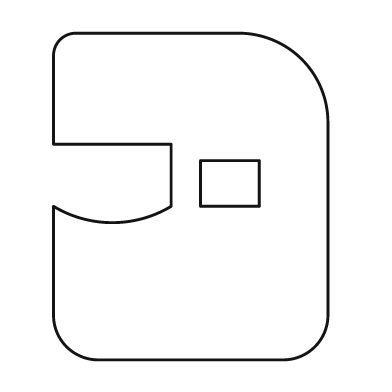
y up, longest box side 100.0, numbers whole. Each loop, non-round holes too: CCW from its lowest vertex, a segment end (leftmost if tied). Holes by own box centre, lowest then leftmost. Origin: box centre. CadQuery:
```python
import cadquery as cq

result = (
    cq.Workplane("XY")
    .moveTo(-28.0, -50.0)
    .lineTo(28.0, -50.0)
    .threePointArc((38.0, -46.0), (42.0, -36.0))
    .lineTo(42.0, 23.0)
    .threePointArc((34.0, 42.0), (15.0, 50.0))
    .lineTo(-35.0, 50.0)
    .threePointArc((-40.0, 48.0), (-42.0, 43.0))
    .lineTo(-42.0, 16.0)
    .lineTo(-6.0, 16.0)
    .lineTo(-6.0, -3.0)
    .threePointArc((-24.0, -8.0), (-42.0, -3.0))
    .lineTo(-42.0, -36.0)
    .threePointArc((-38.0, -46.0), (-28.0, -50.0))
    .close()
    .moveTo(3.0, -3.0)
    .lineTo(21.0, -3.0)
    .lineTo(21.0, 11.0)
    .lineTo(3.0, 11.0)
    .close()
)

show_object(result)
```